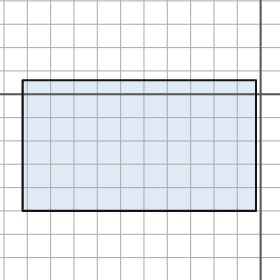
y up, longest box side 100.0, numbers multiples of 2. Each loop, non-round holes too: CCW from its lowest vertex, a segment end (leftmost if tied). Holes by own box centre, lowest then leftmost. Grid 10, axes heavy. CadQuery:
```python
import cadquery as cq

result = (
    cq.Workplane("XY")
    .moveTo(-102.0, -50.0)
    .lineTo(-2.0, -50.0)
    .lineTo(-2.0, 6.0)
    .lineTo(-102.0, 6.0)
    .close()
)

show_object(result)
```